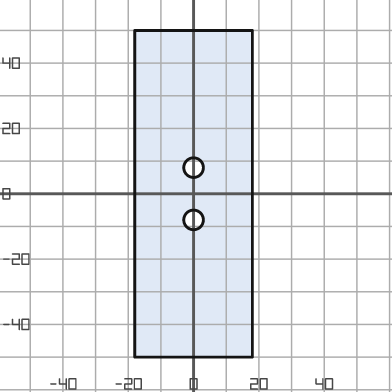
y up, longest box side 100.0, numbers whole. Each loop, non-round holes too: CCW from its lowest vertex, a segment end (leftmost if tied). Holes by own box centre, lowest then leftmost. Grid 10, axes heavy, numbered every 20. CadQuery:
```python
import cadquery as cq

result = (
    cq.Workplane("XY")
    .moveTo(-18.0, -50.0)
    .lineTo(18.0, -50.0)
    .lineTo(18.0, 50.0)
    .lineTo(-18.0, 50.0)
    .close()
    .moveTo(0.0, -8.0)
    .circle(3.0)
    .moveTo(0.0, 8.0)
    .circle(3.0)
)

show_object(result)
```